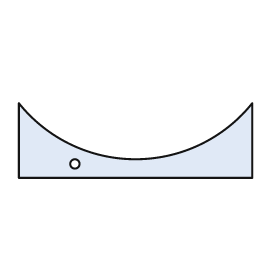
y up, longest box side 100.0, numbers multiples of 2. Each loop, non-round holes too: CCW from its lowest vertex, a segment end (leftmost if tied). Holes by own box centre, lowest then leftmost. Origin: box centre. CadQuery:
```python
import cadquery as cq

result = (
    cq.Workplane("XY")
    .moveTo(-50.0, -16.0)
    .lineTo(50.0, -16.0)
    .lineTo(50.0, 16.0)
    .threePointArc((0.0, -8.0), (-50.0, 16.0))
    .close()
    .moveTo(-26.0, -10.0)
    .circle(2.0)
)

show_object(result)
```